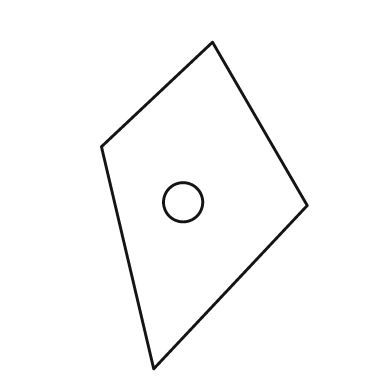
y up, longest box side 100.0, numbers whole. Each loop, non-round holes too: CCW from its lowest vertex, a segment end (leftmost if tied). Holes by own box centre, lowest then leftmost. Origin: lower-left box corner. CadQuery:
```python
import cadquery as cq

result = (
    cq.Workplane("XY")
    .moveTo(16.0, 0.0)
    .lineTo(63.0, 50.0)
    .lineTo(34.0, 100.0)
    .lineTo(0.0, 68.0)
    .close()
    .moveTo(25.0, 51.0)
    .circle(6.0)
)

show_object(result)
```